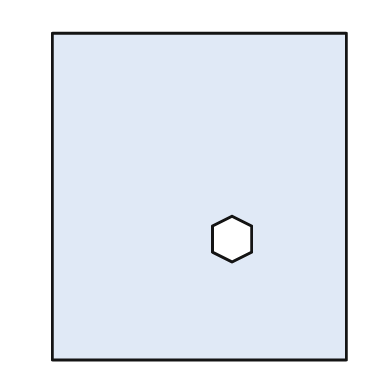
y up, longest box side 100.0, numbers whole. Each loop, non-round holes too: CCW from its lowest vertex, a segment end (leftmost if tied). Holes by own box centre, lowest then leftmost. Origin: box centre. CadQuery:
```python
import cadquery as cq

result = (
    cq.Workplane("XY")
    .moveTo(-45.0, -50.0)
    .lineTo(45.0, -50.0)
    .lineTo(45.0, 50.0)
    .lineTo(-45.0, 50.0)
    .close()
    .moveTo(10.0, -20.0)
    .lineTo(16.0, -17.0)
    .lineTo(16.0, -9.0)
    .lineTo(10.0, -6.0)
    .lineTo(4.0, -9.0)
    .lineTo(4.0, -17.0)
    .close()
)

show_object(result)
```